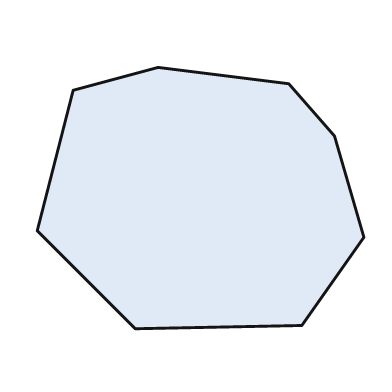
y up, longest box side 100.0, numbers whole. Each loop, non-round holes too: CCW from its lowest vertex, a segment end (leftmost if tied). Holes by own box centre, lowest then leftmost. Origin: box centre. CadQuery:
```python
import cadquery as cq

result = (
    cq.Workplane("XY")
    .moveTo(-20.0, -40.0)
    .lineTo(31.0, -39.0)
    .lineTo(50.0, -12.0)
    .lineTo(41.0, 19.0)
    .lineTo(27.0, 35.0)
    .lineTo(-13.0, 40.0)
    .lineTo(-39.0, 33.0)
    .lineTo(-50.0, -10.0)
    .close()
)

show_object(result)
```